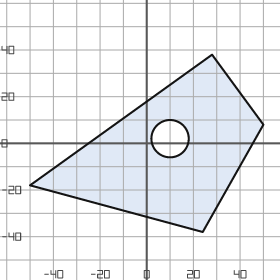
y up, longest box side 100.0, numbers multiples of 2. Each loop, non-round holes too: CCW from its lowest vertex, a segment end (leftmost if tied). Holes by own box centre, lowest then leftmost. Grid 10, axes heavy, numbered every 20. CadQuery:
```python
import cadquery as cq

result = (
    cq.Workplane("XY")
    .moveTo(24.0, -38.0)
    .lineTo(50.0, 8.0)
    .lineTo(28.0, 38.0)
    .lineTo(-50.0, -18.0)
    .close()
    .moveTo(10.0, 2.0)
    .circle(8.0)
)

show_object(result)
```